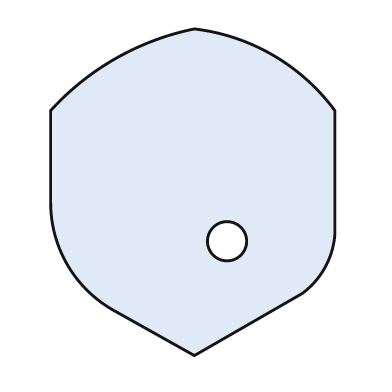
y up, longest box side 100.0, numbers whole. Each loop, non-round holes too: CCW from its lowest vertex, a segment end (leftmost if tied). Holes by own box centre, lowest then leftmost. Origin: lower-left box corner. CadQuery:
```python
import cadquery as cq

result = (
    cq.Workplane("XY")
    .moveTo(44.0, 0.0)
    .lineTo(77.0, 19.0)
    .threePointArc((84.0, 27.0), (87.0, 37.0))
    .lineTo(87.0, 75.0)
    .threePointArc((68.0, 92.0), (44.0, 100.0))
    .threePointArc((20.0, 91.0), (0.0, 75.0))
    .lineTo(0.0, 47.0)
    .threePointArc((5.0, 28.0), (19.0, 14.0))
    .close()
    .moveTo(54.0, 35.0)
    .circle(6.0)
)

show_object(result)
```